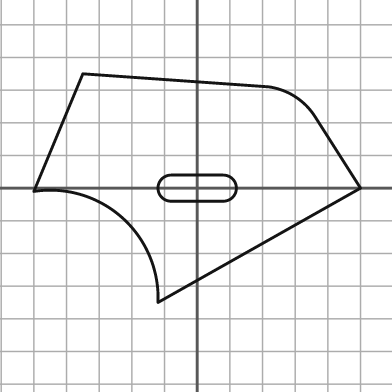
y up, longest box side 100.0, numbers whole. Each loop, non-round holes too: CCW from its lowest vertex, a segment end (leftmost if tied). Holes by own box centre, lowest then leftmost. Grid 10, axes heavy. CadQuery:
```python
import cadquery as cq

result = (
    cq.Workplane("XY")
    .moveTo(-12.0, -35.0)
    .lineTo(50.0, 0.0)
    .lineTo(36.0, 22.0)
    .threePointArc((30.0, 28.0), (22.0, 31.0))
    .lineTo(-35.0, 35.0)
    .lineTo(-50.0, -1.0)
    .threePointArc((-23.0, -9.0), (-12.0, -35.0))
    .close()
    .moveTo(-8.0, -4.0)
    .lineTo(8.0, -4.0)
    .threePointArc((12.0, 0.0), (8.0, 4.0))
    .lineTo(-8.0, 4.0)
    .threePointArc((-12.0, 0.0), (-8.0, -4.0))
    .close()
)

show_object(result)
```